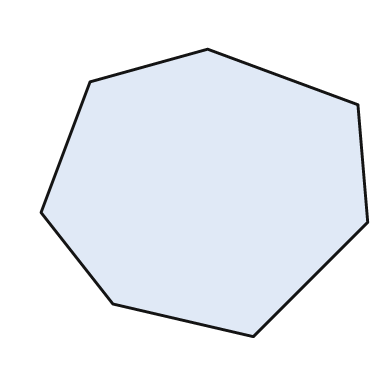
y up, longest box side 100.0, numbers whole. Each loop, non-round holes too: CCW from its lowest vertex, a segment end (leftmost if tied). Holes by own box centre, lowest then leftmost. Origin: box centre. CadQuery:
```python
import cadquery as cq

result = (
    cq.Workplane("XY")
    .moveTo(15.0, -44.0)
    .lineTo(50.0, -9.0)
    .lineTo(47.0, 27.0)
    .lineTo(1.0, 44.0)
    .lineTo(-35.0, 34.0)
    .lineTo(-50.0, -6.0)
    .lineTo(-28.0, -34.0)
    .close()
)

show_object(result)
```